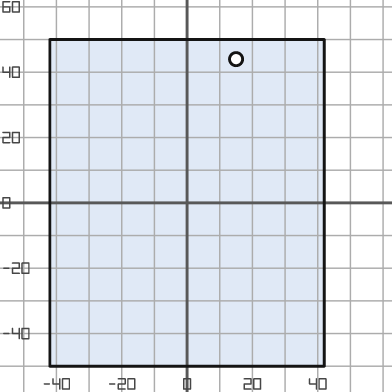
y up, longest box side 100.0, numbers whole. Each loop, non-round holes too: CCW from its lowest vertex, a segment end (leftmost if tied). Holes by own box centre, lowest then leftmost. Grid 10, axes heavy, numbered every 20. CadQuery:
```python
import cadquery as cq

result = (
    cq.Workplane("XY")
    .moveTo(-42.0, -50.0)
    .lineTo(42.0, -50.0)
    .lineTo(42.0, 50.0)
    .lineTo(-42.0, 50.0)
    .close()
    .moveTo(15.0, 44.0)
    .circle(2.0)
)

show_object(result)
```